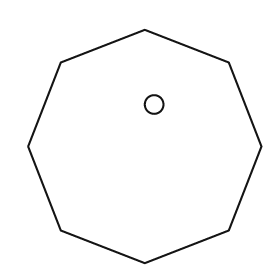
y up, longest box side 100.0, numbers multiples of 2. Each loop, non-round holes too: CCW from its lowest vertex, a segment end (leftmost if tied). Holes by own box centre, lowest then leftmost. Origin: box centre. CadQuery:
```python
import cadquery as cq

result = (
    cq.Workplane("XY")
    .moveTo(0.0, -50.0)
    .lineTo(36.0, -36.0)
    .lineTo(50.0, 0.0)
    .lineTo(36.0, 36.0)
    .lineTo(0.0, 50.0)
    .lineTo(-36.0, 36.0)
    .lineTo(-50.0, 0.0)
    .lineTo(-36.0, -36.0)
    .close()
    .moveTo(4.0, 18.0)
    .circle(4.0)
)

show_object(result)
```